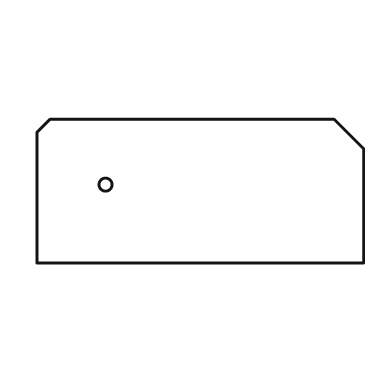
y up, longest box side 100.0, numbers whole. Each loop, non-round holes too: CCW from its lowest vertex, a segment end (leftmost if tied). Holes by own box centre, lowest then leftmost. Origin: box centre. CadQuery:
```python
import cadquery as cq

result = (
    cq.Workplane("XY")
    .moveTo(-50.0, -22.0)
    .lineTo(50.0, -22.0)
    .lineTo(50.0, 13.0)
    .lineTo(41.0, 22.0)
    .lineTo(-46.0, 22.0)
    .lineTo(-50.0, 18.0)
    .close()
    .moveTo(-29.0, 2.0)
    .circle(2.0)
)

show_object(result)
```